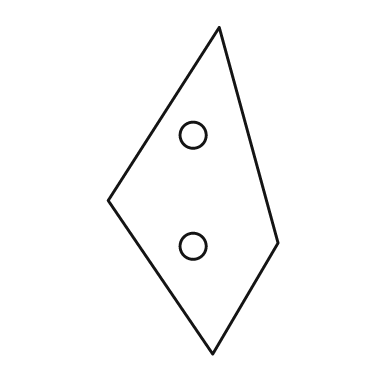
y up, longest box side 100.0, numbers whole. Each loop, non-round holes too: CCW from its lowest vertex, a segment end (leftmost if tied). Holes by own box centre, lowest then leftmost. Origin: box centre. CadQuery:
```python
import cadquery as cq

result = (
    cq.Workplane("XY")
    .moveTo(6.0, -50.0)
    .lineTo(26.0, -16.0)
    .lineTo(8.0, 50.0)
    .lineTo(-26.0, -3.0)
    .close()
    .moveTo(0.0, -17.0)
    .circle(4.0)
    .moveTo(0.0, 17.0)
    .circle(4.0)
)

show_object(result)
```